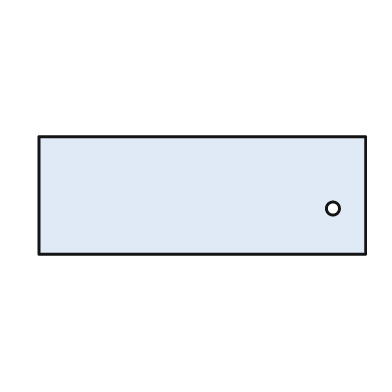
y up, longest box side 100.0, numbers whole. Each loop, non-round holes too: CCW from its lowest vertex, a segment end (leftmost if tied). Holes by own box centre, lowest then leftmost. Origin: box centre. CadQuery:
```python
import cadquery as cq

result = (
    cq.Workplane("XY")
    .moveTo(-50.0, -18.0)
    .lineTo(50.0, -18.0)
    .lineTo(50.0, 18.0)
    .lineTo(-50.0, 18.0)
    .close()
    .moveTo(40.0, -4.0)
    .circle(2.0)
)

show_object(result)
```